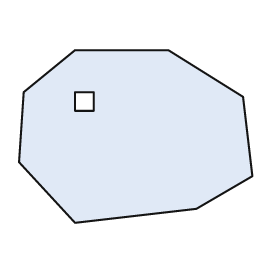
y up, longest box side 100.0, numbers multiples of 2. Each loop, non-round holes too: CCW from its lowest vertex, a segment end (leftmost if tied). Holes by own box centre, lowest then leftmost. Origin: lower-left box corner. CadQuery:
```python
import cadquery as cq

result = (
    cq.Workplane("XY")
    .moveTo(24.0, 0.0)
    .lineTo(76.0, 6.0)
    .lineTo(100.0, 20.0)
    .lineTo(96.0, 54.0)
    .lineTo(64.0, 74.0)
    .lineTo(24.0, 74.0)
    .lineTo(2.0, 56.0)
    .lineTo(0.0, 26.0)
    .close()
    .moveTo(24.0, 48.0)
    .lineTo(32.0, 48.0)
    .lineTo(32.0, 56.0)
    .lineTo(24.0, 56.0)
    .close()
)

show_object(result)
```